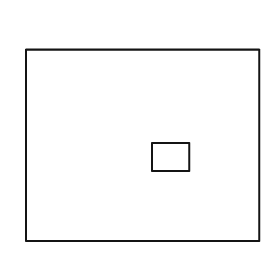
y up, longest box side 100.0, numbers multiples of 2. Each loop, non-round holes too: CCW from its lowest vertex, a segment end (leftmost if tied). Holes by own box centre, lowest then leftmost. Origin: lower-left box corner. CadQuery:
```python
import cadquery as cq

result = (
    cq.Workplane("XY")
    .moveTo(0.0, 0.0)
    .lineTo(100.0, 0.0)
    .lineTo(100.0, 82.0)
    .lineTo(0.0, 82.0)
    .close()
    .moveTo(54.0, 30.0)
    .lineTo(70.0, 30.0)
    .lineTo(70.0, 42.0)
    .lineTo(54.0, 42.0)
    .close()
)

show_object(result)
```